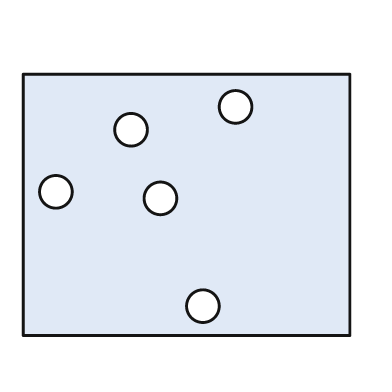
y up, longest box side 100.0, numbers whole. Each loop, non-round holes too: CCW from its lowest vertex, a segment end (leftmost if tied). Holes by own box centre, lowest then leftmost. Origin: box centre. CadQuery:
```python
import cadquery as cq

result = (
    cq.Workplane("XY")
    .moveTo(-50.0, -40.0)
    .lineTo(50.0, -40.0)
    .lineTo(50.0, 40.0)
    .lineTo(-50.0, 40.0)
    .close()
    .moveTo(5.0, -31.0)
    .circle(5.0)
    .moveTo(-8.0, 2.0)
    .circle(5.0)
    .moveTo(-40.0, 4.0)
    .circle(5.0)
    .moveTo(-17.0, 23.0)
    .circle(5.0)
    .moveTo(15.0, 30.0)
    .circle(5.0)
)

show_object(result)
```